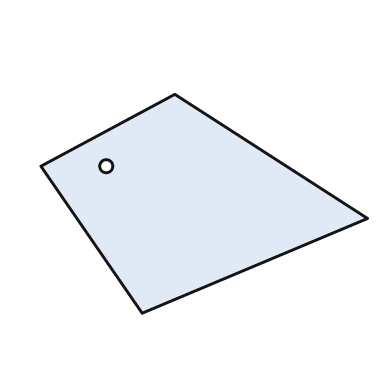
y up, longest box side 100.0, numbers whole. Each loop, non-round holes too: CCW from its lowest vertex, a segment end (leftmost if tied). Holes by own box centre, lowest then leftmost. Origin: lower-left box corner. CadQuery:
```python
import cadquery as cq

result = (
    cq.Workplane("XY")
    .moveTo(31.0, 0.0)
    .lineTo(100.0, 29.0)
    .lineTo(41.0, 67.0)
    .lineTo(0.0, 45.0)
    .close()
    .moveTo(20.0, 45.0)
    .circle(2.0)
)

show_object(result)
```